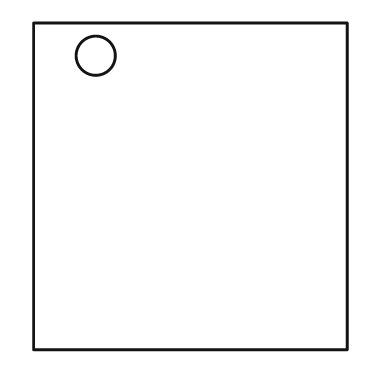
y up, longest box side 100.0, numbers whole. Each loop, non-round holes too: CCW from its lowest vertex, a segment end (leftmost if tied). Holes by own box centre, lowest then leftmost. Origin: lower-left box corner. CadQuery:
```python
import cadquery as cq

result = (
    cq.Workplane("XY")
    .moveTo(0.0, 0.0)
    .lineTo(96.0, 0.0)
    .lineTo(96.0, 100.0)
    .lineTo(0.0, 100.0)
    .close()
    .moveTo(19.0, 90.0)
    .circle(6.0)
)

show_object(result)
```